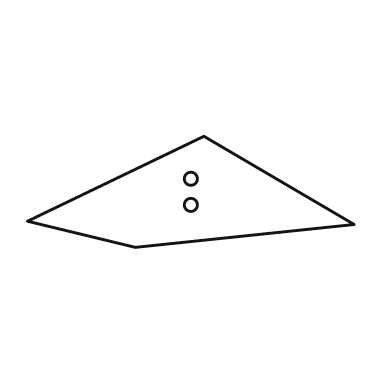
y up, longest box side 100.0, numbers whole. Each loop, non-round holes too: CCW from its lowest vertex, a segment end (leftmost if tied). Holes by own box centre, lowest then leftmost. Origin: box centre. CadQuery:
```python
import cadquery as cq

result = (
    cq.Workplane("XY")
    .moveTo(-17.0, -17.0)
    .lineTo(50.0, -10.0)
    .lineTo(4.0, 17.0)
    .lineTo(-50.0, -9.0)
    .close()
    .moveTo(0.0, -4.0)
    .circle(2.0)
    .moveTo(0.0, 4.0)
    .circle(2.0)
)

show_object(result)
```